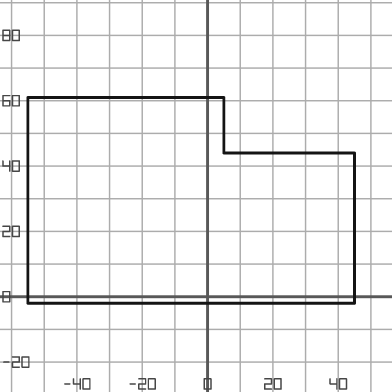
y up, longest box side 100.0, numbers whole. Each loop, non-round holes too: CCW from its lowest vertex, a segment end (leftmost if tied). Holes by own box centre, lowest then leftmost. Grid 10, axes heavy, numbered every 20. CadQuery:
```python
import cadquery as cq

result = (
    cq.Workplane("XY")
    .moveTo(-55.0, -2.0)
    .lineTo(45.0, -2.0)
    .lineTo(45.0, 44.0)
    .lineTo(5.0, 44.0)
    .lineTo(5.0, 61.0)
    .lineTo(-55.0, 61.0)
    .close()
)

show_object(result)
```